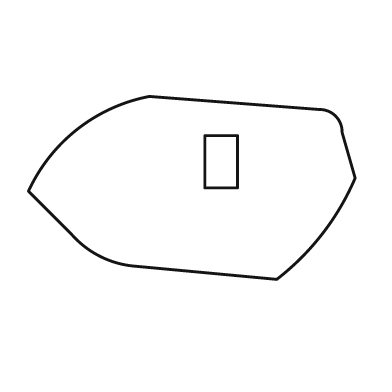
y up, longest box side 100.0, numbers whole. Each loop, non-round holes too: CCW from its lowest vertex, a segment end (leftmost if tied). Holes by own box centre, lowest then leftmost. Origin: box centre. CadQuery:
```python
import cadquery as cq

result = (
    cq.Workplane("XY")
    .moveTo(26.0, -28.0)
    .threePointArc((40.0, -14.0), (50.0, 3.0))
    .lineTo(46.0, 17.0)
    .threePointArc((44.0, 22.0), (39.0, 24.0))
    .lineTo(-13.0, 28.0)
    .threePointArc((-35.0, 18.0), (-50.0, -1.0))
    .lineTo(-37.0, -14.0)
    .threePointArc((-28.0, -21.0), (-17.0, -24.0))
    .close()
    .moveTo(4.0, 0.0)
    .lineTo(14.0, 0.0)
    .lineTo(14.0, 16.0)
    .lineTo(4.0, 16.0)
    .close()
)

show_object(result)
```